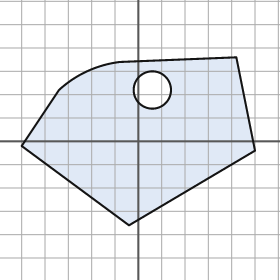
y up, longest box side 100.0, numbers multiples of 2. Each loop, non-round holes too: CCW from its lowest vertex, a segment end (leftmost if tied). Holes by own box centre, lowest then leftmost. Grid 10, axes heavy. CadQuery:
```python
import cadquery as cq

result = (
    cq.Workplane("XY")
    .moveTo(-4.0, -36.0)
    .lineTo(50.0, -4.0)
    .lineTo(42.0, 36.0)
    .lineTo(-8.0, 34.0)
    .threePointArc((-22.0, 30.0), (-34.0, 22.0))
    .lineTo(-50.0, -2.0)
    .close()
    .moveTo(6.0, 22.0)
    .circle(8.0)
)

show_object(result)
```